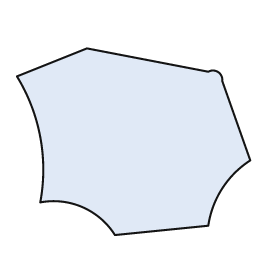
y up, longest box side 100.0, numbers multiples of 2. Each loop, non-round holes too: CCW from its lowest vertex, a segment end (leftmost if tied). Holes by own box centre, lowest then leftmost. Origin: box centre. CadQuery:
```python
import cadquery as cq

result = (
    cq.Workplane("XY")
    .moveTo(-8.0, -40.0)
    .lineTo(32.0, -36.0)
    .threePointArc((38.0, -20.0), (50.0, -8.0))
    .lineTo(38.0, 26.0)
    .threePointArc((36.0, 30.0), (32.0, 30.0))
    .lineTo(-20.0, 40.0)
    .lineTo(-50.0, 28.0)
    .threePointArc((-40.0, 2.0), (-40.0, -26.0))
    .threePointArc((-22.0, -28.0), (-8.0, -40.0))
    .close()
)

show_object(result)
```